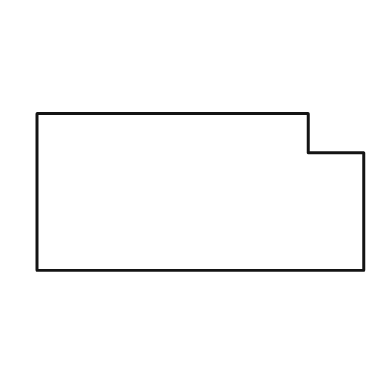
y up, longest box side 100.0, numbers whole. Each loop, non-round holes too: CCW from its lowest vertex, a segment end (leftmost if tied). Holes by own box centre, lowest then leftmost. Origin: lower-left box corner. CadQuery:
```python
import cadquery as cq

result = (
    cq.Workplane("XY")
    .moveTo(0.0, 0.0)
    .lineTo(100.0, 0.0)
    .lineTo(100.0, 36.0)
    .lineTo(83.0, 36.0)
    .lineTo(83.0, 48.0)
    .lineTo(0.0, 48.0)
    .close()
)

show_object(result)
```